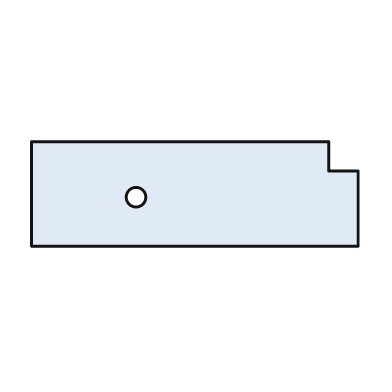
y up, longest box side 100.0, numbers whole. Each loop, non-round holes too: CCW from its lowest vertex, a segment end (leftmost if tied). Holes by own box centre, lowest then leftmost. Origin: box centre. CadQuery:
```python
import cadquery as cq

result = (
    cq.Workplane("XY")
    .moveTo(-50.0, -16.0)
    .lineTo(50.0, -16.0)
    .lineTo(50.0, 7.0)
    .lineTo(41.0, 7.0)
    .lineTo(41.0, 16.0)
    .lineTo(-50.0, 16.0)
    .close()
    .moveTo(-18.0, -1.0)
    .circle(3.0)
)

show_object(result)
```